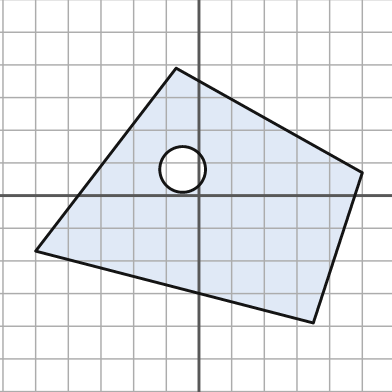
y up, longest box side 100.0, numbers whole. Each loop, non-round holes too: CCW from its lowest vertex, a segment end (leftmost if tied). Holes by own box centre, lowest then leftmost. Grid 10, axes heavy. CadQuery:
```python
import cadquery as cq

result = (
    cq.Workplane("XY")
    .moveTo(35.0, -39.0)
    .lineTo(50.0, 7.0)
    .lineTo(-7.0, 39.0)
    .lineTo(-50.0, -17.0)
    .close()
    .moveTo(-5.0, 8.0)
    .circle(7.0)
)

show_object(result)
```